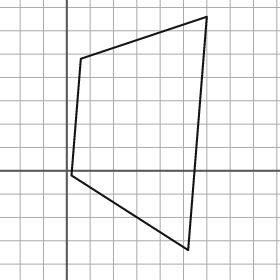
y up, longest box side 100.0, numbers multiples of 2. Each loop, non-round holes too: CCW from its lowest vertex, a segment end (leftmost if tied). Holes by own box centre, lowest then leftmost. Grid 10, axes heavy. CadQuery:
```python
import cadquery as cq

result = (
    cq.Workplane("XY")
    .moveTo(52.0, -34.0)
    .lineTo(60.0, 66.0)
    .lineTo(6.0, 48.0)
    .lineTo(2.0, -2.0)
    .close()
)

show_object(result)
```